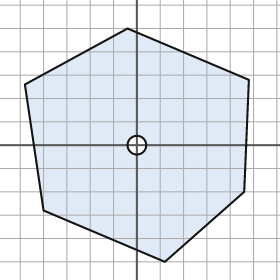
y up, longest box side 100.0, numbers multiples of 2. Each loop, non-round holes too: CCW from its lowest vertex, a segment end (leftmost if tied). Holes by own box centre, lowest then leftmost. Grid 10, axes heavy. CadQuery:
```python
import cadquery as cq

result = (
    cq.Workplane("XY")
    .moveTo(12.0, -50.0)
    .lineTo(46.0, -20.0)
    .lineTo(48.0, 28.0)
    .lineTo(-4.0, 50.0)
    .lineTo(-48.0, 26.0)
    .lineTo(-40.0, -28.0)
    .close()
    .moveTo(0.0, 0.0)
    .circle(4.0)
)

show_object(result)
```